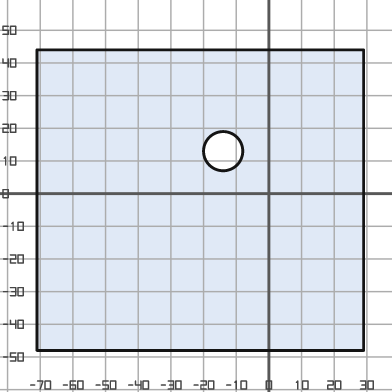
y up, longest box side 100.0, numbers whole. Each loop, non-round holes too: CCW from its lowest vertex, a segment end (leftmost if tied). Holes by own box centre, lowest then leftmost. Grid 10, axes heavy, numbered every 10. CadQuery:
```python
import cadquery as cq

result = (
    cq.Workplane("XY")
    .moveTo(-71.0, -48.0)
    .lineTo(29.0, -48.0)
    .lineTo(29.0, 44.0)
    .lineTo(-71.0, 44.0)
    .close()
    .moveTo(-14.0, 13.0)
    .circle(6.0)
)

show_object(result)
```